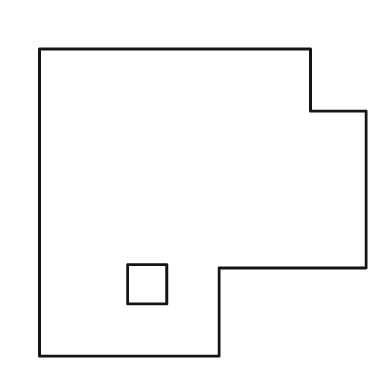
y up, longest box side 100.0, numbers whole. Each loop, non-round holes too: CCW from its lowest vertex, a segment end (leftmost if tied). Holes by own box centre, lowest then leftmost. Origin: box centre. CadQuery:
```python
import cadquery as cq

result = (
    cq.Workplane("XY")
    .moveTo(-50.0, -47.0)
    .lineTo(5.0, -47.0)
    .lineTo(5.0, -20.0)
    .lineTo(50.0, -20.0)
    .lineTo(50.0, 28.0)
    .lineTo(33.0, 28.0)
    .lineTo(33.0, 47.0)
    .lineTo(-50.0, 47.0)
    .close()
    .moveTo(-23.0, -31.0)
    .lineTo(-11.0, -31.0)
    .lineTo(-11.0, -19.0)
    .lineTo(-23.0, -19.0)
    .close()
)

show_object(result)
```